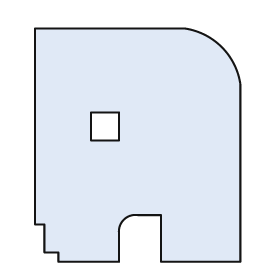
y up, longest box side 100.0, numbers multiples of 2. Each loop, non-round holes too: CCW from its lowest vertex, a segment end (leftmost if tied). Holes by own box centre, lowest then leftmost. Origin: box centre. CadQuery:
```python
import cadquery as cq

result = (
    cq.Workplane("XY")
    .moveTo(-34.0, -50.0)
    .lineTo(-8.0, -50.0)
    .lineTo(-8.0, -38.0)
    .threePointArc((-6.0, -32.0), (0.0, -30.0))
    .lineTo(10.0, -30.0)
    .lineTo(10.0, -50.0)
    .lineTo(44.0, -50.0)
    .lineTo(44.0, 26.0)
    .threePointArc((36.0, 42.0), (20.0, 50.0))
    .lineTo(-44.0, 50.0)
    .lineTo(-44.0, -34.0)
    .lineTo(-40.0, -34.0)
    .lineTo(-40.0, -46.0)
    .lineTo(-34.0, -46.0)
    .close()
    .moveTo(-20.0, 2.0)
    .lineTo(-8.0, 2.0)
    .lineTo(-8.0, 14.0)
    .lineTo(-20.0, 14.0)
    .close()
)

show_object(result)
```